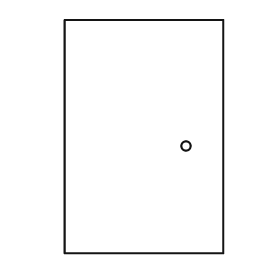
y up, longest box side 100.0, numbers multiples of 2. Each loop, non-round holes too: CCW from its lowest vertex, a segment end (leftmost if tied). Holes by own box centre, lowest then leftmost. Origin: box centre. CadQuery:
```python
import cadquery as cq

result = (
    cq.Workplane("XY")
    .moveTo(-34.0, -50.0)
    .lineTo(34.0, -50.0)
    .lineTo(34.0, 50.0)
    .lineTo(-34.0, 50.0)
    .close()
    .moveTo(18.0, -4.0)
    .circle(2.0)
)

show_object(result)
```